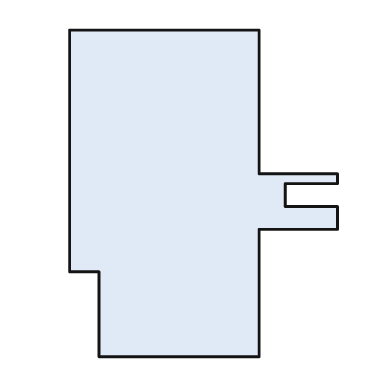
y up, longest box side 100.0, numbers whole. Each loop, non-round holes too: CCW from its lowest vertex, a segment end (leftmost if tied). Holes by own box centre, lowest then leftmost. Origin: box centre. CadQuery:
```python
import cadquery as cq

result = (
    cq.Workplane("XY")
    .moveTo(-32.0, -50.0)
    .lineTo(17.0, -50.0)
    .lineTo(17.0, -11.0)
    .lineTo(41.0, -11.0)
    .lineTo(41.0, -4.0)
    .lineTo(25.0, -4.0)
    .lineTo(25.0, 3.0)
    .lineTo(41.0, 3.0)
    .lineTo(41.0, 6.0)
    .lineTo(17.0, 6.0)
    .lineTo(17.0, 50.0)
    .lineTo(-41.0, 50.0)
    .lineTo(-41.0, -24.0)
    .lineTo(-32.0, -24.0)
    .close()
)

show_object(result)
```